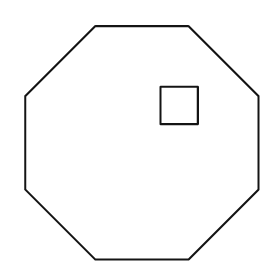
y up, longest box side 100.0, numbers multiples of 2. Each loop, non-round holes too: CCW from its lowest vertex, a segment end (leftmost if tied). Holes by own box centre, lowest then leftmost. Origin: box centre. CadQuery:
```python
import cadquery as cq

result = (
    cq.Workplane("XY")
    .moveTo(-20.0, -50.0)
    .lineTo(20.0, -50.0)
    .lineTo(50.0, -20.0)
    .lineTo(50.0, 20.0)
    .lineTo(20.0, 50.0)
    .lineTo(-20.0, 50.0)
    .lineTo(-50.0, 20.0)
    .lineTo(-50.0, -20.0)
    .close()
    .moveTo(8.0, 8.0)
    .lineTo(24.0, 8.0)
    .lineTo(24.0, 24.0)
    .lineTo(8.0, 24.0)
    .close()
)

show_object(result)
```